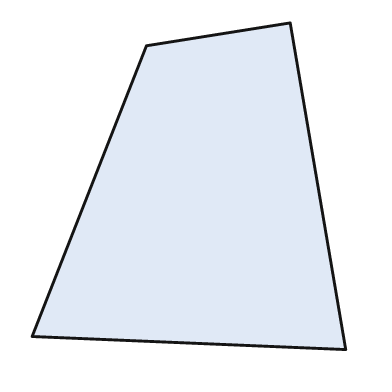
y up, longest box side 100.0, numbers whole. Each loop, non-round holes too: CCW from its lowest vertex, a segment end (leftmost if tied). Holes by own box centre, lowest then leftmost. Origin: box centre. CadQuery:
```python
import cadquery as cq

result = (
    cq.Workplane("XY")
    .moveTo(48.0, -50.0)
    .lineTo(31.0, 50.0)
    .lineTo(-13.0, 43.0)
    .lineTo(-48.0, -46.0)
    .close()
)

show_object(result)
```